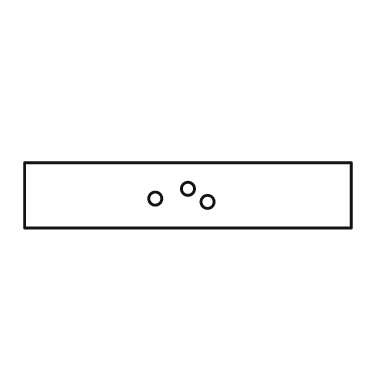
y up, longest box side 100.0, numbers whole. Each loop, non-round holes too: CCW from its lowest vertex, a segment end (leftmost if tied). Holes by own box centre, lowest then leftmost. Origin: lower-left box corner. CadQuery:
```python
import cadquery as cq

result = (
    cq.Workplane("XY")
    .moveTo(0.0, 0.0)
    .lineTo(100.0, 0.0)
    .lineTo(100.0, 20.0)
    .lineTo(0.0, 20.0)
    .close()
    .moveTo(56.0, 8.0)
    .circle(2.0)
    .moveTo(40.0, 9.0)
    .circle(2.0)
    .moveTo(50.0, 12.0)
    .circle(2.0)
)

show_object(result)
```